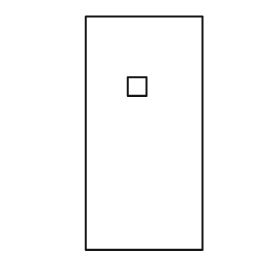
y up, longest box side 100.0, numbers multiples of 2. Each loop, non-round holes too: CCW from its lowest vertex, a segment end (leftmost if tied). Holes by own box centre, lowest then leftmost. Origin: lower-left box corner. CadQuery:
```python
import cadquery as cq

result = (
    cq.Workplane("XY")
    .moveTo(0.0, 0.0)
    .lineTo(50.0, 0.0)
    .lineTo(50.0, 100.0)
    .lineTo(0.0, 100.0)
    .close()
    .moveTo(18.0, 66.0)
    .lineTo(26.0, 66.0)
    .lineTo(26.0, 74.0)
    .lineTo(18.0, 74.0)
    .close()
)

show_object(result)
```